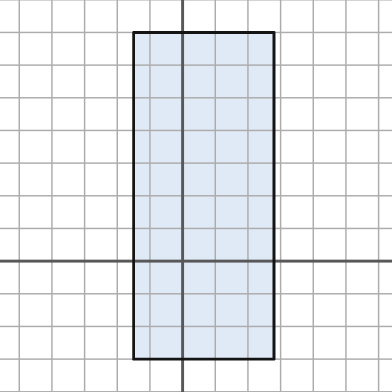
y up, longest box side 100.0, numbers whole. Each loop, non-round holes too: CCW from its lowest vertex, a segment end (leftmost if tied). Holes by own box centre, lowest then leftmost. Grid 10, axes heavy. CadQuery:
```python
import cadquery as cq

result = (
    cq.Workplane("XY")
    .moveTo(-15.0, -30.0)
    .lineTo(28.0, -30.0)
    .lineTo(28.0, 70.0)
    .lineTo(-15.0, 70.0)
    .close()
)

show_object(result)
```